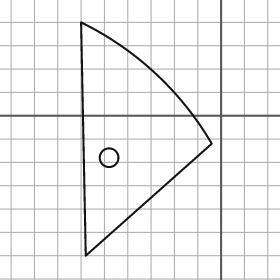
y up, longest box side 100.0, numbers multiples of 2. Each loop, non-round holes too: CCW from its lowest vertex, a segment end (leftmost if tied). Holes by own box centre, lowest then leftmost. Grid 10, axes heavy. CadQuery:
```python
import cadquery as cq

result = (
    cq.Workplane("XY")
    .moveTo(-58.0, -60.0)
    .lineTo(-4.0, -12.0)
    .threePointArc((-28.0, 18.0), (-60.0, 40.0))
    .close()
    .moveTo(-48.0, -18.0)
    .circle(4.0)
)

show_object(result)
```